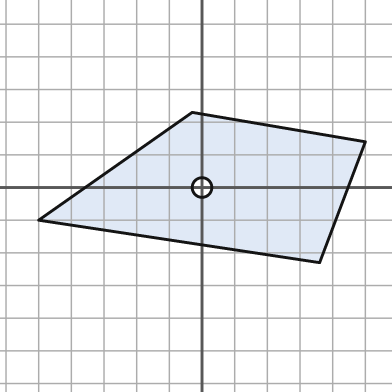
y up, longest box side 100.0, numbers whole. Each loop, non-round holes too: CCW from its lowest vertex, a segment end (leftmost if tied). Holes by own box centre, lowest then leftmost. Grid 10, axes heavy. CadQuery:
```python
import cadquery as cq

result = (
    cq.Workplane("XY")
    .moveTo(36.0, -23.0)
    .lineTo(50.0, 14.0)
    .lineTo(-3.0, 23.0)
    .lineTo(-50.0, -10.0)
    .close()
    .moveTo(0.0, 0.0)
    .circle(3.0)
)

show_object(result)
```